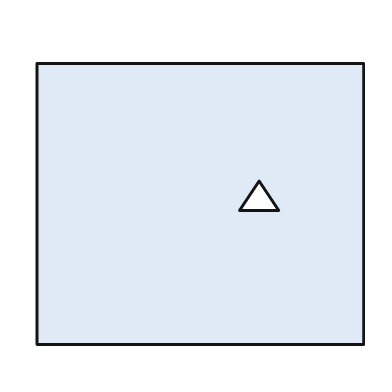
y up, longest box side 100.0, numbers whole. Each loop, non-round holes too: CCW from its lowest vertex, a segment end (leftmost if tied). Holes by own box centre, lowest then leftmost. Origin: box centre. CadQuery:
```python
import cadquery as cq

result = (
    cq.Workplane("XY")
    .moveTo(-50.0, -43.0)
    .lineTo(50.0, -43.0)
    .lineTo(50.0, 43.0)
    .lineTo(-50.0, 43.0)
    .close()
    .moveTo(12.0, -2.0)
    .lineTo(24.0, -2.0)
    .lineTo(18.0, 7.0)
    .close()
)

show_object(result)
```